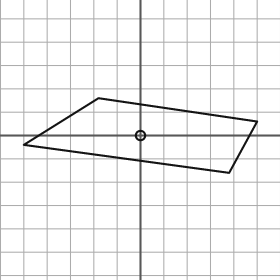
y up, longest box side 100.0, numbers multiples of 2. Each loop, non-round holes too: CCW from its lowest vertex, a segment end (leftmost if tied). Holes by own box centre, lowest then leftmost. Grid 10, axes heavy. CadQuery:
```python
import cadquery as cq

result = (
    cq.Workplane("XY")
    .moveTo(38.0, -16.0)
    .lineTo(50.0, 6.0)
    .lineTo(-18.0, 16.0)
    .lineTo(-50.0, -4.0)
    .close()
    .moveTo(0.0, 0.0)
    .circle(2.0)
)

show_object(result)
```